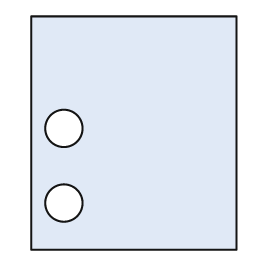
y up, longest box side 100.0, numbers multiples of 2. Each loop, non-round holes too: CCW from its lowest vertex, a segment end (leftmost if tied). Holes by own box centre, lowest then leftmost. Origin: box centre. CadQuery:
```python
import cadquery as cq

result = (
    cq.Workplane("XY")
    .moveTo(-44.0, -50.0)
    .lineTo(44.0, -50.0)
    .lineTo(44.0, 50.0)
    .lineTo(-44.0, 50.0)
    .close()
    .moveTo(-30.0, -30.0)
    .circle(8.0)
    .moveTo(-30.0, 2.0)
    .circle(8.0)
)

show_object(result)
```